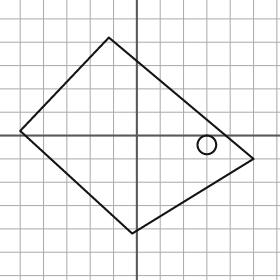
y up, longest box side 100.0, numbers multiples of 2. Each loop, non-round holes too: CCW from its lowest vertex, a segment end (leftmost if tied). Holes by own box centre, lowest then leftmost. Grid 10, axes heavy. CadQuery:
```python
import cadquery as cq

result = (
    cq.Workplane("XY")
    .moveTo(-2.0, -42.0)
    .lineTo(50.0, -10.0)
    .lineTo(-12.0, 42.0)
    .lineTo(-50.0, 2.0)
    .close()
    .moveTo(30.0, -4.0)
    .circle(4.0)
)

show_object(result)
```